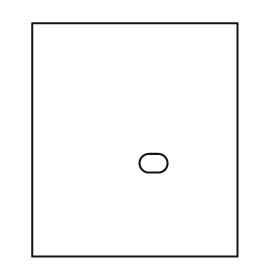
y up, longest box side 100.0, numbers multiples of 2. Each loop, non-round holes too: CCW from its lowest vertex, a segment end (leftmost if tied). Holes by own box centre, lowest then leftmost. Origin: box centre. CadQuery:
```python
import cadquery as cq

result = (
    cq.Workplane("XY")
    .moveTo(-44.0, -50.0)
    .lineTo(44.0, -50.0)
    .lineTo(44.0, 50.0)
    .lineTo(-44.0, 50.0)
    .close()
    .moveTo(6.0, -14.0)
    .lineTo(10.0, -14.0)
    .threePointArc((14.0, -10.0), (10.0, -6.0))
    .lineTo(6.0, -6.0)
    .threePointArc((2.0, -10.0), (6.0, -14.0))
    .close()
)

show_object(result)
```